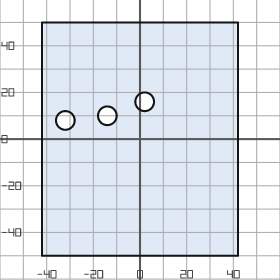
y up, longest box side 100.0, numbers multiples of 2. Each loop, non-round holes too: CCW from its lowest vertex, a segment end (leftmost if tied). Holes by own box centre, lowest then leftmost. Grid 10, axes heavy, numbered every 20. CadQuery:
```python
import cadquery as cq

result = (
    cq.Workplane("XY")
    .moveTo(-42.0, -50.0)
    .lineTo(42.0, -50.0)
    .lineTo(42.0, 50.0)
    .lineTo(-42.0, 50.0)
    .close()
    .moveTo(-32.0, 8.0)
    .circle(4.0)
    .moveTo(-14.0, 10.0)
    .circle(4.0)
    .moveTo(2.0, 16.0)
    .circle(4.0)
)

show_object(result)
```